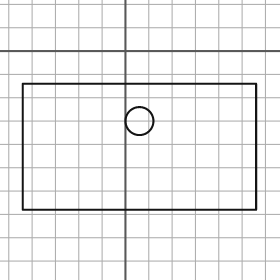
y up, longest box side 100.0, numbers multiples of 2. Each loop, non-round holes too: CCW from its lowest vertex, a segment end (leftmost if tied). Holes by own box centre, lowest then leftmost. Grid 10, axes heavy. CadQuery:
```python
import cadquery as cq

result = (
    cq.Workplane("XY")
    .moveTo(-44.0, -68.0)
    .lineTo(56.0, -68.0)
    .lineTo(56.0, -14.0)
    .lineTo(-44.0, -14.0)
    .close()
    .moveTo(6.0, -30.0)
    .circle(6.0)
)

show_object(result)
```